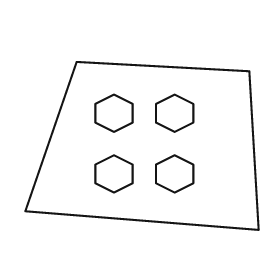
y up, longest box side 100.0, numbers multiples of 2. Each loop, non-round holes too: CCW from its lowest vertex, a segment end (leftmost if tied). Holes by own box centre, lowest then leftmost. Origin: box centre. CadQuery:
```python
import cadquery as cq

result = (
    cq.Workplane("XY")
    .moveTo(50.0, -36.0)
    .lineTo(46.0, 32.0)
    .lineTo(-28.0, 36.0)
    .lineTo(-50.0, -28.0)
    .close()
    .moveTo(-12.0, -20.0)
    .lineTo(-4.0, -16.0)
    .lineTo(-4.0, -8.0)
    .lineTo(-12.0, -4.0)
    .lineTo(-20.0, -8.0)
    .lineTo(-20.0, -16.0)
    .close()
    .moveTo(14.0, -20.0)
    .lineTo(22.0, -16.0)
    .lineTo(22.0, -8.0)
    .lineTo(14.0, -4.0)
    .lineTo(6.0, -8.0)
    .lineTo(6.0, -16.0)
    .close()
    .moveTo(-12.0, 6.0)
    .lineTo(-4.0, 10.0)
    .lineTo(-4.0, 18.0)
    .lineTo(-12.0, 22.0)
    .lineTo(-20.0, 18.0)
    .lineTo(-20.0, 10.0)
    .close()
    .moveTo(14.0, 6.0)
    .lineTo(22.0, 10.0)
    .lineTo(22.0, 18.0)
    .lineTo(14.0, 22.0)
    .lineTo(6.0, 18.0)
    .lineTo(6.0, 10.0)
    .close()
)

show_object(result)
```